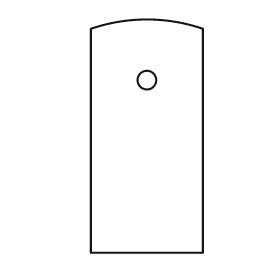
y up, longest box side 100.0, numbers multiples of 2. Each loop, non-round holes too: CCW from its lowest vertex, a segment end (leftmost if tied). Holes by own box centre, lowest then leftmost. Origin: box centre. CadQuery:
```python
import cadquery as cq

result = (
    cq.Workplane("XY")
    .moveTo(-24.0, -50.0)
    .lineTo(24.0, -50.0)
    .lineTo(24.0, 46.0)
    .threePointArc((0.0, 50.0), (-24.0, 46.0))
    .close()
    .moveTo(0.0, 24.0)
    .circle(4.0)
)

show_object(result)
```